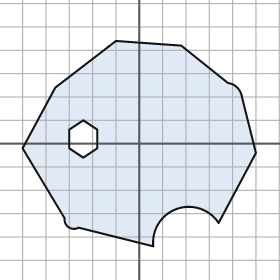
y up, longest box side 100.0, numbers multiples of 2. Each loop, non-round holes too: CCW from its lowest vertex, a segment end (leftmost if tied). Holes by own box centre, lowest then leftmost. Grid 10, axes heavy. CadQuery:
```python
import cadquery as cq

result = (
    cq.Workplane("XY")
    .moveTo(6.0, -44.0)
    .threePointArc((16.0, -28.0), (34.0, -34.0))
    .lineTo(50.0, -4.0)
    .lineTo(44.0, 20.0)
    .threePointArc((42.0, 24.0), (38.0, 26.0))
    .lineTo(18.0, 42.0)
    .lineTo(-10.0, 44.0)
    .lineTo(-36.0, 24.0)
    .lineTo(-50.0, -2.0)
    .lineTo(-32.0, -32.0)
    .threePointArc((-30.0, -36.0), (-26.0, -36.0))
    .close()
    .moveTo(-24.0, -6.0)
    .lineTo(-18.0, -2.0)
    .lineTo(-18.0, 6.0)
    .lineTo(-24.0, 10.0)
    .lineTo(-30.0, 6.0)
    .lineTo(-30.0, -2.0)
    .close()
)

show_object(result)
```